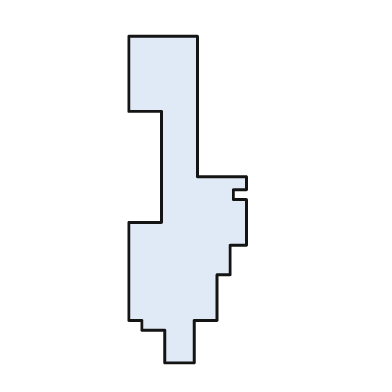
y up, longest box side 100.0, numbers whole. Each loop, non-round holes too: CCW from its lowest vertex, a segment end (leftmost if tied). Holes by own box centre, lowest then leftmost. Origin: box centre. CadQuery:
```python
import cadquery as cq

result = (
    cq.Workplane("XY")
    .moveTo(-7.0, -50.0)
    .lineTo(2.0, -50.0)
    .lineTo(2.0, -37.0)
    .lineTo(9.0, -37.0)
    .lineTo(9.0, -23.0)
    .lineTo(13.0, -23.0)
    .lineTo(13.0, -14.0)
    .lineTo(18.0, -14.0)
    .lineTo(18.0, 0.0)
    .lineTo(14.0, 0.0)
    .lineTo(14.0, 3.0)
    .lineTo(18.0, 3.0)
    .lineTo(18.0, 7.0)
    .lineTo(3.0, 7.0)
    .lineTo(3.0, 50.0)
    .lineTo(-18.0, 50.0)
    .lineTo(-18.0, 27.0)
    .lineTo(-8.0, 27.0)
    .lineTo(-8.0, -7.0)
    .lineTo(-18.0, -7.0)
    .lineTo(-18.0, -37.0)
    .lineTo(-14.0, -37.0)
    .lineTo(-14.0, -40.0)
    .lineTo(-7.0, -40.0)
    .close()
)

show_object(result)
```